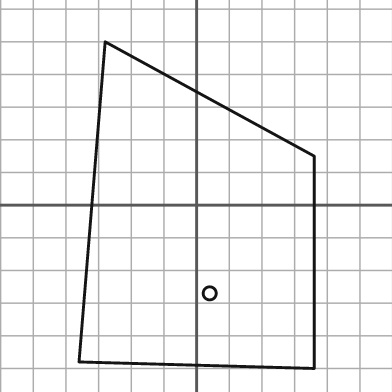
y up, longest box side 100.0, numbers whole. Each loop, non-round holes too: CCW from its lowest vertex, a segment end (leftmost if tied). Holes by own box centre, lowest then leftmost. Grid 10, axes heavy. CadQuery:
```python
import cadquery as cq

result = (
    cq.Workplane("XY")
    .moveTo(36.0, -50.0)
    .lineTo(36.0, 15.0)
    .lineTo(-28.0, 50.0)
    .lineTo(-36.0, -48.0)
    .close()
    .moveTo(4.0, -27.0)
    .circle(2.0)
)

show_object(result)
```